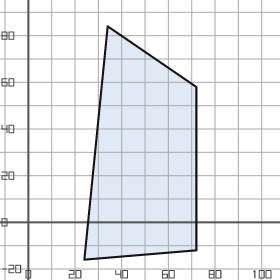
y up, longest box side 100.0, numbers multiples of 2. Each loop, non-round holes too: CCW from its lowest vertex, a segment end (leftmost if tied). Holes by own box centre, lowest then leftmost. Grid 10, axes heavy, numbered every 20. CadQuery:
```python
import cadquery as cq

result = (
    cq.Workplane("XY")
    .moveTo(24.0, -16.0)
    .lineTo(72.0, -12.0)
    .lineTo(72.0, 58.0)
    .lineTo(34.0, 84.0)
    .close()
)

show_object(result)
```